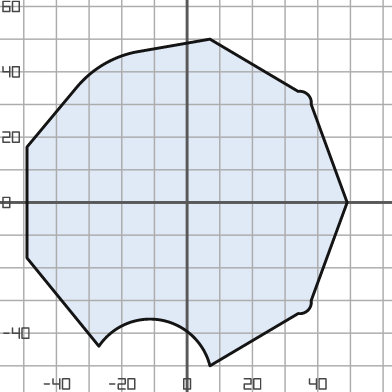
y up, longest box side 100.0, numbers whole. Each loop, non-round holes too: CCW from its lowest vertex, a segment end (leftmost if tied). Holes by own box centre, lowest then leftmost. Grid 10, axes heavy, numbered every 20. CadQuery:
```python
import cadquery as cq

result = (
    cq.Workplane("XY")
    .moveTo(7.0, -50.0)
    .lineTo(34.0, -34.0)
    .threePointArc((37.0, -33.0), (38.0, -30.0))
    .lineTo(49.0, 0.0)
    .lineTo(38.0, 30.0)
    .threePointArc((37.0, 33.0), (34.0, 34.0))
    .lineTo(7.0, 50.0)
    .lineTo(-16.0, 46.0)
    .threePointArc((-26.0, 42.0), (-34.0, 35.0))
    .lineTo(-49.0, 17.0)
    .lineTo(-49.0, -17.0)
    .lineTo(-27.0, -44.0)
    .threePointArc((-8.0, -36.0), (7.0, -50.0))
    .close()
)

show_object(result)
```